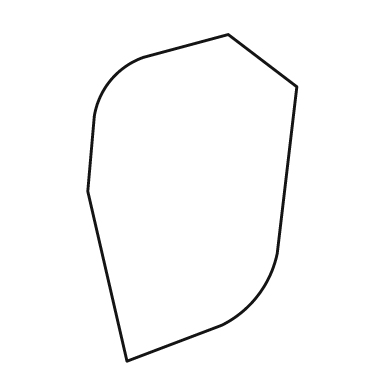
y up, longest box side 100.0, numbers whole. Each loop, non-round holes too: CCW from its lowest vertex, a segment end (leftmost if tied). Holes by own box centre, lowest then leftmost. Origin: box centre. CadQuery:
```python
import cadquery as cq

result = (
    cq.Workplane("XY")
    .moveTo(-20.0, -50.0)
    .lineTo(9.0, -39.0)
    .threePointArc((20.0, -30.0), (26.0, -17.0))
    .lineTo(32.0, 34.0)
    .lineTo(11.0, 50.0)
    .lineTo(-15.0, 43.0)
    .threePointArc((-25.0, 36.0), (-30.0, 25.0))
    .lineTo(-32.0, 2.0)
    .close()
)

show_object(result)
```